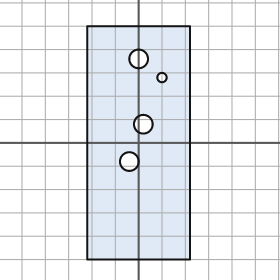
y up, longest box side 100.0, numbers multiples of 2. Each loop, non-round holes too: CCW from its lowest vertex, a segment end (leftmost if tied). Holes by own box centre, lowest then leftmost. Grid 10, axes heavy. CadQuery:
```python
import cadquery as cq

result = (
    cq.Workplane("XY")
    .moveTo(-22.0, -50.0)
    .lineTo(22.0, -50.0)
    .lineTo(22.0, 50.0)
    .lineTo(-22.0, 50.0)
    .close()
    .moveTo(-4.0, -8.0)
    .circle(4.0)
    .moveTo(2.0, 8.0)
    .circle(4.0)
    .moveTo(10.0, 28.0)
    .circle(2.0)
    .moveTo(0.0, 36.0)
    .circle(4.0)
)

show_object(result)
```